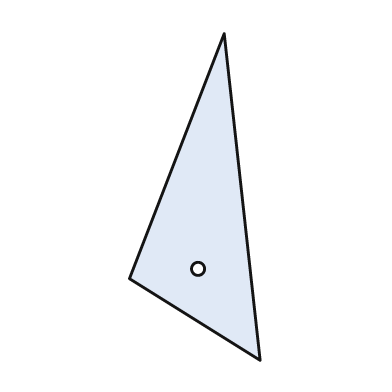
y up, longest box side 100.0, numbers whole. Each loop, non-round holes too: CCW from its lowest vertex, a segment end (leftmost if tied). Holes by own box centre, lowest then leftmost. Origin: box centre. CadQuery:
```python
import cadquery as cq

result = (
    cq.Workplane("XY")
    .moveTo(20.0, -50.0)
    .lineTo(9.0, 50.0)
    .lineTo(-20.0, -25.0)
    .close()
    .moveTo(1.0, -22.0)
    .circle(2.0)
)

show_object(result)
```